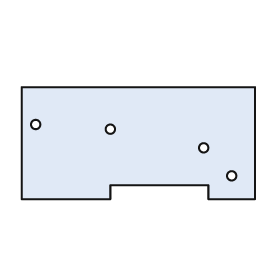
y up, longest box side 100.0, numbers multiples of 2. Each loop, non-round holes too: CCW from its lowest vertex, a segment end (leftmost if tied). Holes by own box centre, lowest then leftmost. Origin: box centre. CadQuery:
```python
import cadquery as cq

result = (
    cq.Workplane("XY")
    .moveTo(-50.0, -24.0)
    .lineTo(-12.0, -24.0)
    .lineTo(-12.0, -18.0)
    .lineTo(30.0, -18.0)
    .lineTo(30.0, -24.0)
    .lineTo(50.0, -24.0)
    .lineTo(50.0, 24.0)
    .lineTo(-50.0, 24.0)
    .close()
    .moveTo(40.0, -14.0)
    .circle(2.0)
    .moveTo(28.0, -2.0)
    .circle(2.0)
    .moveTo(-12.0, 6.0)
    .circle(2.0)
    .moveTo(-44.0, 8.0)
    .circle(2.0)
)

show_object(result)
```